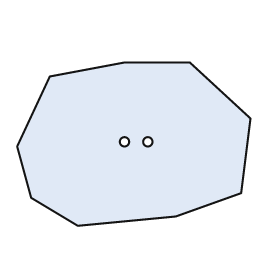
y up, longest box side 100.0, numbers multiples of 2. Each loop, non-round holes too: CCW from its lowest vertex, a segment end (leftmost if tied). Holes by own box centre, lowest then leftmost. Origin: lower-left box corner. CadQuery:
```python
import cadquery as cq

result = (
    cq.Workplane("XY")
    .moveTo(26.0, 0.0)
    .lineTo(68.0, 4.0)
    .lineTo(96.0, 14.0)
    .lineTo(100.0, 46.0)
    .lineTo(74.0, 70.0)
    .lineTo(46.0, 70.0)
    .lineTo(14.0, 64.0)
    .lineTo(0.0, 34.0)
    .lineTo(6.0, 12.0)
    .close()
    .moveTo(46.0, 36.0)
    .circle(2.0)
    .moveTo(56.0, 36.0)
    .circle(2.0)
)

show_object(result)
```